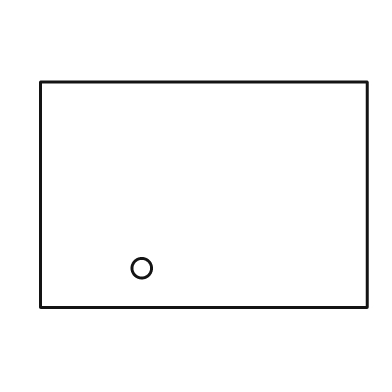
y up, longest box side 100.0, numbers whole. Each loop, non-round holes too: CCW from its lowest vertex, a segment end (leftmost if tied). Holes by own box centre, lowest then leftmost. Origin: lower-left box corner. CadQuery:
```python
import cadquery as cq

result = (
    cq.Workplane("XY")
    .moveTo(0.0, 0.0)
    .lineTo(100.0, 0.0)
    .lineTo(100.0, 69.0)
    .lineTo(0.0, 69.0)
    .close()
    .moveTo(31.0, 12.0)
    .circle(3.0)
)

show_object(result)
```